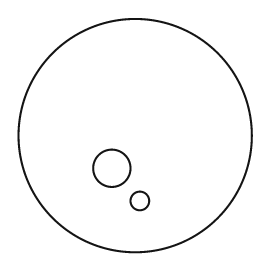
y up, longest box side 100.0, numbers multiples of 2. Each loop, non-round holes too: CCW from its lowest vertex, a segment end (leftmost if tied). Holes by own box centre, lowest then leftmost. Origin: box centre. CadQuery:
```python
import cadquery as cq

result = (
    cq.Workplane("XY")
    .moveTo(0.0, 0.0)
    .circle(50.0)
    .moveTo(2.0, -28.0)
    .circle(4.0)
    .moveTo(-10.0, -14.0)
    .circle(8.0)
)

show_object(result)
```